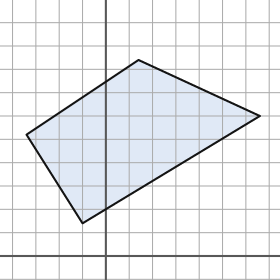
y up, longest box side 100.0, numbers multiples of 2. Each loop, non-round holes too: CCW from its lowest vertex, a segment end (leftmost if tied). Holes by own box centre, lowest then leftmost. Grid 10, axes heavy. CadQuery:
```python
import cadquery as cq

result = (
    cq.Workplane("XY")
    .moveTo(-10.0, 14.0)
    .lineTo(66.0, 60.0)
    .lineTo(14.0, 84.0)
    .lineTo(-34.0, 52.0)
    .close()
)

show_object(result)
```